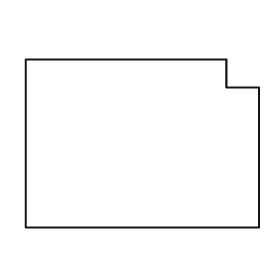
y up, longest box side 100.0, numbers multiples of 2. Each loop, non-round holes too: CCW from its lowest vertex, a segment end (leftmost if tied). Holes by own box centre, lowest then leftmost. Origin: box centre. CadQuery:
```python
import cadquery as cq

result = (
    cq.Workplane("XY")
    .moveTo(-50.0, -36.0)
    .lineTo(50.0, -36.0)
    .lineTo(50.0, 24.0)
    .lineTo(36.0, 24.0)
    .lineTo(36.0, 36.0)
    .lineTo(-50.0, 36.0)
    .close()
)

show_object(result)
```